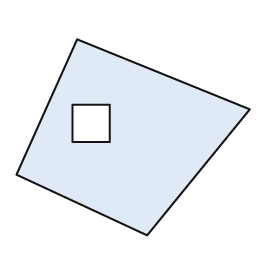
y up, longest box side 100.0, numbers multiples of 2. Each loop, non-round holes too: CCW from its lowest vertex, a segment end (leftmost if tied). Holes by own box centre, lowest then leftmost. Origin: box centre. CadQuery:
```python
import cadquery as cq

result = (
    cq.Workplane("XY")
    .moveTo(6.0, -42.0)
    .lineTo(50.0, 12.0)
    .lineTo(-24.0, 42.0)
    .lineTo(-50.0, -16.0)
    .close()
    .moveTo(-26.0, -2.0)
    .lineTo(-10.0, -2.0)
    .lineTo(-10.0, 14.0)
    .lineTo(-26.0, 14.0)
    .close()
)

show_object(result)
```